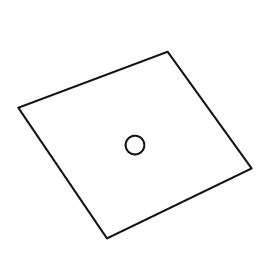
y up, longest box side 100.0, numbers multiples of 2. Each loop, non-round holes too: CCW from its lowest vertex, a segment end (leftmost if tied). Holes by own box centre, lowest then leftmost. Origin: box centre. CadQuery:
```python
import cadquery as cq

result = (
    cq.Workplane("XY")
    .moveTo(-12.0, -40.0)
    .lineTo(50.0, -10.0)
    .lineTo(14.0, 40.0)
    .lineTo(-50.0, 16.0)
    .close()
    .moveTo(0.0, 0.0)
    .circle(4.0)
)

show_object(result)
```